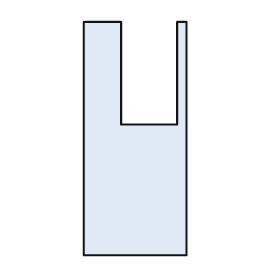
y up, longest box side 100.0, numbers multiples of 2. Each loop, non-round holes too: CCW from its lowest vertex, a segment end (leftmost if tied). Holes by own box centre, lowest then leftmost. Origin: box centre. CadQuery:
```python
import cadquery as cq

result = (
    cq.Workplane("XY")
    .moveTo(-22.0, -50.0)
    .lineTo(22.0, -50.0)
    .lineTo(22.0, 50.0)
    .lineTo(18.0, 50.0)
    .lineTo(18.0, 6.0)
    .lineTo(-6.0, 6.0)
    .lineTo(-6.0, 50.0)
    .lineTo(-22.0, 50.0)
    .close()
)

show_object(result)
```